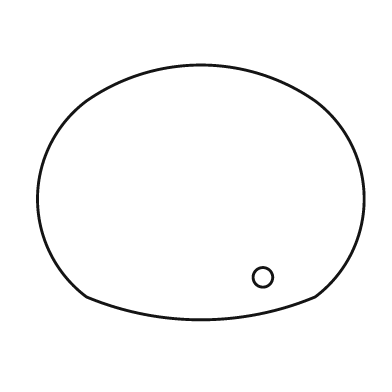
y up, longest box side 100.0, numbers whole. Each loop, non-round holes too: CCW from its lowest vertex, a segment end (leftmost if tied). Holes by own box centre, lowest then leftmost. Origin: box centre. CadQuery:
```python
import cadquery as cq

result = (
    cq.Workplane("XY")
    .moveTo(-35.0, -32.0)
    .threePointArc((0.0, -39.0), (35.0, -32.0))
    .threePointArc((50.0, -2.0), (35.0, 28.0))
    .threePointArc((0.0, 39.0), (-35.0, 28.0))
    .threePointArc((-50.0, -2.0), (-35.0, -32.0))
    .close()
    .moveTo(19.0, -26.0)
    .circle(3.0)
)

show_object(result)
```